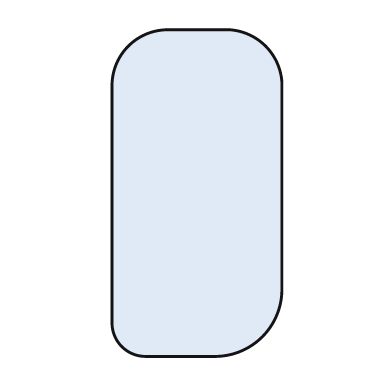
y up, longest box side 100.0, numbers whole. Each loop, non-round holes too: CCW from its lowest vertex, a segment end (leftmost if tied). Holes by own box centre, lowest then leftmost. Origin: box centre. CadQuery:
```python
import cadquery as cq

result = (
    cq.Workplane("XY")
    .moveTo(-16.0, -50.0)
    .lineTo(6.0, -50.0)
    .threePointArc((20.0, -44.0), (26.0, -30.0))
    .lineTo(26.0, 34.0)
    .threePointArc((21.0, 45.0), (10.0, 50.0))
    .lineTo(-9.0, 50.0)
    .threePointArc((-21.0, 45.0), (-26.0, 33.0))
    .lineTo(-26.0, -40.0)
    .threePointArc((-23.0, -47.0), (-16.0, -50.0))
    .close()
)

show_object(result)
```